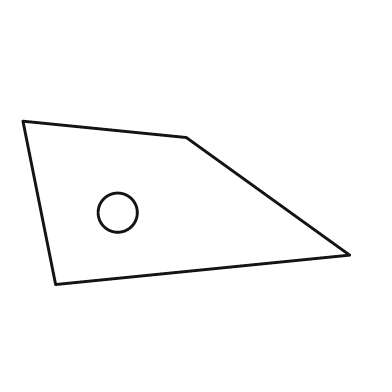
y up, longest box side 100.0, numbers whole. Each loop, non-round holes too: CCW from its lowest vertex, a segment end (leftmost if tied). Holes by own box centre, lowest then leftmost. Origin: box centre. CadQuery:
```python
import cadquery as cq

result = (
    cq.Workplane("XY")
    .moveTo(-40.0, -25.0)
    .lineTo(50.0, -16.0)
    .lineTo(0.0, 20.0)
    .lineTo(-50.0, 25.0)
    .close()
    .moveTo(-21.0, -3.0)
    .circle(6.0)
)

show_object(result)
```